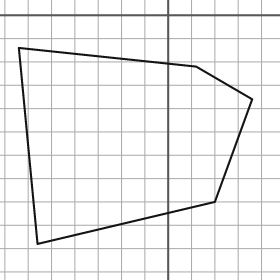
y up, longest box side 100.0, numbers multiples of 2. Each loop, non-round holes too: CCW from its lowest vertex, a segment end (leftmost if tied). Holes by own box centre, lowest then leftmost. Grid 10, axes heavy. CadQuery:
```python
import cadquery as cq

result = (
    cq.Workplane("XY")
    .moveTo(-56.0, -98.0)
    .lineTo(20.0, -80.0)
    .lineTo(36.0, -36.0)
    .lineTo(12.0, -22.0)
    .lineTo(-64.0, -14.0)
    .close()
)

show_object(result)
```